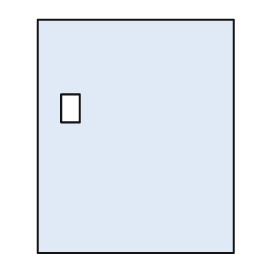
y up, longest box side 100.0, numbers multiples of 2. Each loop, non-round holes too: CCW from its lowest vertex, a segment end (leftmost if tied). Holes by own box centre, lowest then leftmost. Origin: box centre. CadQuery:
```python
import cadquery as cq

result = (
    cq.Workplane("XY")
    .moveTo(-42.0, -50.0)
    .lineTo(42.0, -50.0)
    .lineTo(42.0, 50.0)
    .lineTo(-42.0, 50.0)
    .close()
    .moveTo(-32.0, 6.0)
    .lineTo(-24.0, 6.0)
    .lineTo(-24.0, 18.0)
    .lineTo(-32.0, 18.0)
    .close()
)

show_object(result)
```